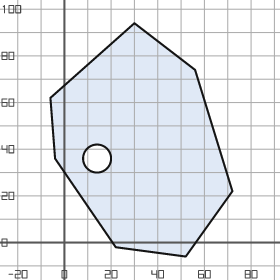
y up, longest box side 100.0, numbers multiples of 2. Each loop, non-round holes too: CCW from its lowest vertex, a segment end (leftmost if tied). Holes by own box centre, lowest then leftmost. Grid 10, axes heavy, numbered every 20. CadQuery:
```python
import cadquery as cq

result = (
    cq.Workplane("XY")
    .moveTo(52.0, -6.0)
    .lineTo(72.0, 22.0)
    .lineTo(56.0, 74.0)
    .lineTo(30.0, 94.0)
    .lineTo(-6.0, 62.0)
    .lineTo(-4.0, 36.0)
    .lineTo(22.0, -2.0)
    .close()
    .moveTo(14.0, 36.0)
    .circle(6.0)
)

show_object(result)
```